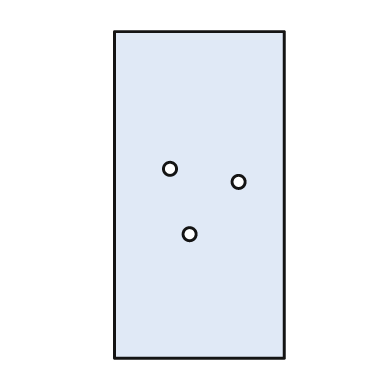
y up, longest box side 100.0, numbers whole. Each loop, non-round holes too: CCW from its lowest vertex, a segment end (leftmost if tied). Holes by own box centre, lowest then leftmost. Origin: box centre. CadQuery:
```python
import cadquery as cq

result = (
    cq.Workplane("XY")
    .moveTo(-26.0, -50.0)
    .lineTo(26.0, -50.0)
    .lineTo(26.0, 50.0)
    .lineTo(-26.0, 50.0)
    .close()
    .moveTo(-3.0, -12.0)
    .circle(2.0)
    .moveTo(12.0, 4.0)
    .circle(2.0)
    .moveTo(-9.0, 8.0)
    .circle(2.0)
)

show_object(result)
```